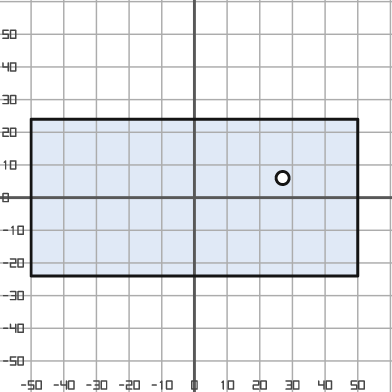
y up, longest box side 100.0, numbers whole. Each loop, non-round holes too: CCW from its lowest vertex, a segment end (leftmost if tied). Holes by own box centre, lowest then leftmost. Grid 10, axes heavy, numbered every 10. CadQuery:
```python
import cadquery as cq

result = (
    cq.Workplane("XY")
    .moveTo(-50.0, -24.0)
    .lineTo(50.0, -24.0)
    .lineTo(50.0, 24.0)
    .lineTo(-50.0, 24.0)
    .close()
    .moveTo(27.0, 6.0)
    .circle(2.0)
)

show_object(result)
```